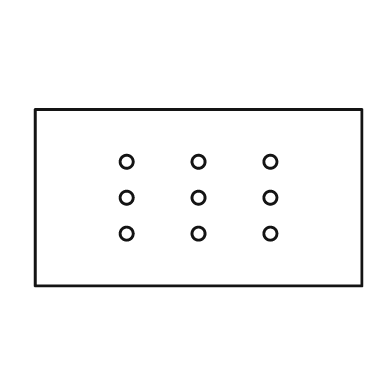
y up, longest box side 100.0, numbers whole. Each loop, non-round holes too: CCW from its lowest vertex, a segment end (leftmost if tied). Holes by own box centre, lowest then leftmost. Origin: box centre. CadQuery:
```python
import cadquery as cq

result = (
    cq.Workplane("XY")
    .moveTo(-50.0, -27.0)
    .lineTo(50.0, -27.0)
    .lineTo(50.0, 27.0)
    .lineTo(-50.0, 27.0)
    .close()
    .moveTo(-22.0, -11.0)
    .circle(2.0)
    .moveTo(0.0, -11.0)
    .circle(2.0)
    .moveTo(22.0, -11.0)
    .circle(2.0)
    .moveTo(-22.0, 0.0)
    .circle(2.0)
    .moveTo(0.0, 0.0)
    .circle(2.0)
    .moveTo(22.0, 0.0)
    .circle(2.0)
    .moveTo(-22.0, 11.0)
    .circle(2.0)
    .moveTo(0.0, 11.0)
    .circle(2.0)
    .moveTo(22.0, 11.0)
    .circle(2.0)
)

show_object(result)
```